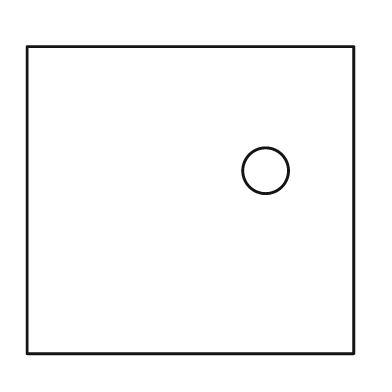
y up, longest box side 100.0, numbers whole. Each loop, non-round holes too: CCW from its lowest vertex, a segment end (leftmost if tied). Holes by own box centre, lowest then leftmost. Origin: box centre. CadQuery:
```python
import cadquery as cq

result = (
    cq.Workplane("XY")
    .moveTo(-50.0, -47.0)
    .lineTo(50.0, -47.0)
    .lineTo(50.0, 47.0)
    .lineTo(-50.0, 47.0)
    .close()
    .moveTo(23.0, 9.0)
    .circle(7.0)
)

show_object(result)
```